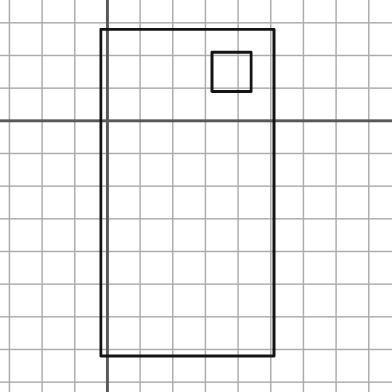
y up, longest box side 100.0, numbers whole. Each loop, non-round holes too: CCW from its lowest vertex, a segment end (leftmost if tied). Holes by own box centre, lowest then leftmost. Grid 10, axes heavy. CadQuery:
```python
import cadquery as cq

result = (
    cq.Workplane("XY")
    .moveTo(-2.0, -72.0)
    .lineTo(51.0, -72.0)
    .lineTo(51.0, 28.0)
    .lineTo(-2.0, 28.0)
    .close()
    .moveTo(32.0, 9.0)
    .lineTo(44.0, 9.0)
    .lineTo(44.0, 21.0)
    .lineTo(32.0, 21.0)
    .close()
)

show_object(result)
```